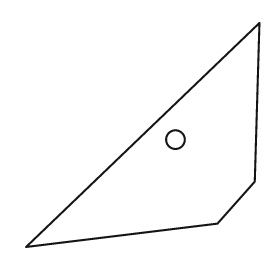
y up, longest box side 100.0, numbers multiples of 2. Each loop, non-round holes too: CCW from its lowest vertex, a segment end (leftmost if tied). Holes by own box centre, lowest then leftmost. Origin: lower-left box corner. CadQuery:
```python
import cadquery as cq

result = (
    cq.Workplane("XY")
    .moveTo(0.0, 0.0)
    .lineTo(82.0, 10.0)
    .lineTo(98.0, 28.0)
    .lineTo(100.0, 96.0)
    .close()
    .moveTo(64.0, 46.0)
    .circle(4.0)
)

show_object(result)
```